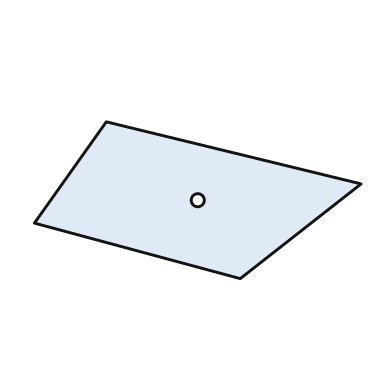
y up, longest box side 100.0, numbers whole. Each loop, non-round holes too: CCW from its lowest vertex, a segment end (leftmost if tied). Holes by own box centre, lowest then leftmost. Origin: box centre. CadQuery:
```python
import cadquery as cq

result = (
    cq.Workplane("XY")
    .moveTo(13.0, -24.0)
    .lineTo(50.0, 5.0)
    .lineTo(-28.0, 24.0)
    .lineTo(-50.0, -7.0)
    .close()
    .moveTo(0.0, 0.0)
    .circle(2.0)
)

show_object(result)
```